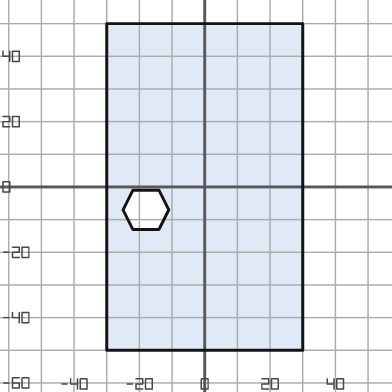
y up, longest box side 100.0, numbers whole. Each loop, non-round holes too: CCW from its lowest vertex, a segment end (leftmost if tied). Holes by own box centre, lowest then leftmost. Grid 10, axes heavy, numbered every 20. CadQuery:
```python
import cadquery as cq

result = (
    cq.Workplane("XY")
    .moveTo(-30.0, -50.0)
    .lineTo(30.0, -50.0)
    .lineTo(30.0, 50.0)
    .lineTo(-30.0, 50.0)
    .close()
    .moveTo(-22.0, -13.0)
    .lineTo(-14.0, -13.0)
    .lineTo(-11.0, -7.0)
    .lineTo(-14.0, -1.0)
    .lineTo(-22.0, -1.0)
    .lineTo(-25.0, -7.0)
    .close()
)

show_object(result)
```